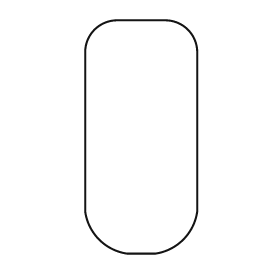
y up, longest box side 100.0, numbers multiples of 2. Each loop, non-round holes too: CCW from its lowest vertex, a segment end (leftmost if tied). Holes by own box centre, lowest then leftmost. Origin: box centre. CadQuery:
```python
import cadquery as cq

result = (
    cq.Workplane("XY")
    .moveTo(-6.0, -50.0)
    .lineTo(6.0, -50.0)
    .threePointArc((18.0, -44.0), (24.0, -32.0))
    .lineTo(24.0, 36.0)
    .threePointArc((20.0, 46.0), (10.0, 50.0))
    .lineTo(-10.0, 50.0)
    .threePointArc((-20.0, 46.0), (-24.0, 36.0))
    .lineTo(-24.0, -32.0)
    .threePointArc((-18.0, -44.0), (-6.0, -50.0))
    .close()
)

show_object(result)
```